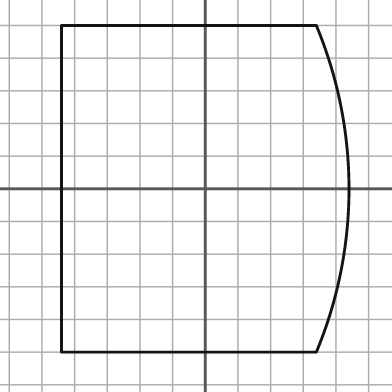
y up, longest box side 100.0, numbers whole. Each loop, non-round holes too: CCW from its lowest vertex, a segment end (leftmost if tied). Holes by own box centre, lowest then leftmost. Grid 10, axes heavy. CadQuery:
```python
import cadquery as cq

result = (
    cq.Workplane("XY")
    .moveTo(-44.0, -50.0)
    .lineTo(34.0, -50.0)
    .threePointArc((44.0, 0.0), (34.0, 50.0))
    .lineTo(-44.0, 50.0)
    .close()
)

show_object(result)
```